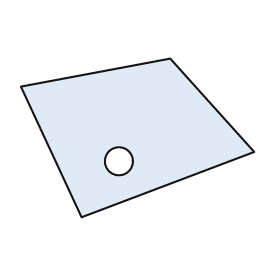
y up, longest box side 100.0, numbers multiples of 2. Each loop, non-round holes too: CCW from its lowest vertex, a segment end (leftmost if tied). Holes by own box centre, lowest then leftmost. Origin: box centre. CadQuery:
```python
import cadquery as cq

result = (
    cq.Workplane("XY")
    .moveTo(-24.0, -34.0)
    .lineTo(50.0, -6.0)
    .lineTo(14.0, 34.0)
    .lineTo(-50.0, 22.0)
    .close()
    .moveTo(-8.0, -10.0)
    .circle(6.0)
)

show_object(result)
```